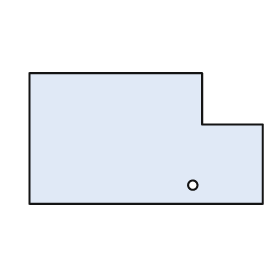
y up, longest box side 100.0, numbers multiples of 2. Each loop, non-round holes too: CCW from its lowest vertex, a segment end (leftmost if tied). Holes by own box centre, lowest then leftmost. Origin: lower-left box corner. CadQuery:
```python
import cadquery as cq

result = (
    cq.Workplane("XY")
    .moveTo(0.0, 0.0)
    .lineTo(100.0, 0.0)
    .lineTo(100.0, 34.0)
    .lineTo(74.0, 34.0)
    .lineTo(74.0, 56.0)
    .lineTo(0.0, 56.0)
    .close()
    .moveTo(70.0, 8.0)
    .circle(2.0)
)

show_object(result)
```